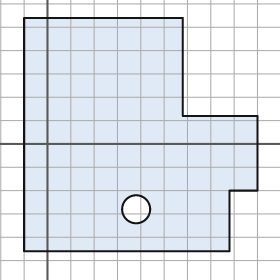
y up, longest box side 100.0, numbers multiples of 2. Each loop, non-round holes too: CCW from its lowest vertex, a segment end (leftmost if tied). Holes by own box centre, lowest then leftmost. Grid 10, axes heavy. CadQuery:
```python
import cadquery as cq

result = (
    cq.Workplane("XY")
    .moveTo(-10.0, -46.0)
    .lineTo(78.0, -46.0)
    .lineTo(78.0, -20.0)
    .lineTo(90.0, -20.0)
    .lineTo(90.0, 12.0)
    .lineTo(58.0, 12.0)
    .lineTo(58.0, 54.0)
    .lineTo(-10.0, 54.0)
    .close()
    .moveTo(38.0, -28.0)
    .circle(6.0)
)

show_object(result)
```